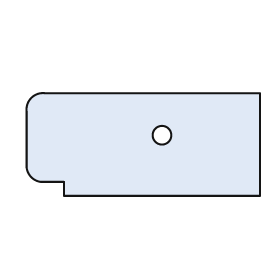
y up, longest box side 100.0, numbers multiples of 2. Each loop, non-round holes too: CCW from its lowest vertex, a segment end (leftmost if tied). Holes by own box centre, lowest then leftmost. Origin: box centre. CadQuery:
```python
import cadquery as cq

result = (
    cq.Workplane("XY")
    .moveTo(-34.0, -22.0)
    .lineTo(50.0, -22.0)
    .lineTo(50.0, 22.0)
    .lineTo(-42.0, 22.0)
    .threePointArc((-48.0, 20.0), (-50.0, 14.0))
    .lineTo(-50.0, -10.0)
    .threePointArc((-48.0, -14.0), (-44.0, -16.0))
    .lineTo(-34.0, -16.0)
    .close()
    .moveTo(8.0, 4.0)
    .circle(4.0)
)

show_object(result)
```